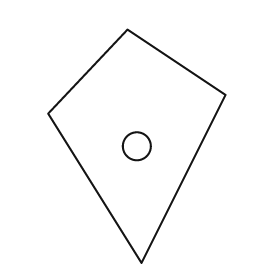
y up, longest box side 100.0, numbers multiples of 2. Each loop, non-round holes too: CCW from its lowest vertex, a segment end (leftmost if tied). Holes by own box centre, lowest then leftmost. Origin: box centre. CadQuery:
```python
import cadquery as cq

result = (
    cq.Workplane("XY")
    .moveTo(2.0, -50.0)
    .lineTo(38.0, 22.0)
    .lineTo(-4.0, 50.0)
    .lineTo(-38.0, 14.0)
    .close()
    .moveTo(0.0, 0.0)
    .circle(6.0)
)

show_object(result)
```